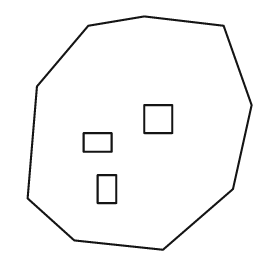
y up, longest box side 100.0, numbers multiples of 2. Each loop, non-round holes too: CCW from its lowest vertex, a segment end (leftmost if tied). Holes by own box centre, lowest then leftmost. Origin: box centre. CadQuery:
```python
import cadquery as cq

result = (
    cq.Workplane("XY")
    .moveTo(10.0, -50.0)
    .lineTo(40.0, -24.0)
    .lineTo(48.0, 12.0)
    .lineTo(36.0, 46.0)
    .lineTo(2.0, 50.0)
    .lineTo(-22.0, 46.0)
    .lineTo(-44.0, 20.0)
    .lineTo(-48.0, -28.0)
    .lineTo(-28.0, -46.0)
    .close()
    .moveTo(-18.0, -30.0)
    .lineTo(-10.0, -30.0)
    .lineTo(-10.0, -18.0)
    .lineTo(-18.0, -18.0)
    .close()
    .moveTo(-24.0, -8.0)
    .lineTo(-12.0, -8.0)
    .lineTo(-12.0, 0.0)
    .lineTo(-24.0, 0.0)
    .close()
    .moveTo(2.0, 0.0)
    .lineTo(14.0, 0.0)
    .lineTo(14.0, 12.0)
    .lineTo(2.0, 12.0)
    .close()
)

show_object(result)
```